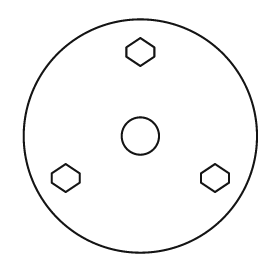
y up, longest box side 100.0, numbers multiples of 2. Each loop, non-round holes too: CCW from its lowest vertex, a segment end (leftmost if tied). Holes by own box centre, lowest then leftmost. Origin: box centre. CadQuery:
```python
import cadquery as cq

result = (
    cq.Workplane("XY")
    .moveTo(0.0, 0.0)
    .circle(50.0)
    .moveTo(-32.0, -24.0)
    .lineTo(-26.0, -20.0)
    .lineTo(-26.0, -16.0)
    .lineTo(-32.0, -12.0)
    .lineTo(-38.0, -16.0)
    .lineTo(-38.0, -20.0)
    .close()
    .moveTo(32.0, -24.0)
    .lineTo(38.0, -20.0)
    .lineTo(38.0, -16.0)
    .lineTo(32.0, -12.0)
    .lineTo(26.0, -16.0)
    .lineTo(26.0, -20.0)
    .close()
    .moveTo(0.0, 0.0)
    .circle(8.0)
    .moveTo(0.0, 30.0)
    .lineTo(6.0, 34.0)
    .lineTo(6.0, 38.0)
    .lineTo(0.0, 42.0)
    .lineTo(-6.0, 38.0)
    .lineTo(-6.0, 34.0)
    .close()
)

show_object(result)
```